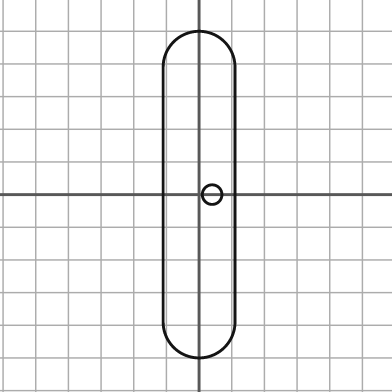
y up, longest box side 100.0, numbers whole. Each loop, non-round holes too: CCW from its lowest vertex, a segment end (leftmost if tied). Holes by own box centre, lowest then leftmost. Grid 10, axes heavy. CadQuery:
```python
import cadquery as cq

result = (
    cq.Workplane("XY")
    .moveTo(-11.0, -39.0)
    .threePointArc((0.0, -50.0), (11.0, -39.0))
    .lineTo(11.0, 39.0)
    .threePointArc((0.0, 50.0), (-11.0, 39.0))
    .close()
    .moveTo(4.0, 0.0)
    .circle(3.0)
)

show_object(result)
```